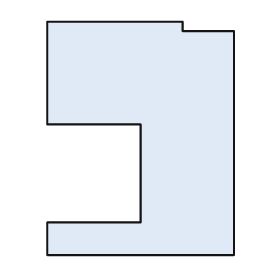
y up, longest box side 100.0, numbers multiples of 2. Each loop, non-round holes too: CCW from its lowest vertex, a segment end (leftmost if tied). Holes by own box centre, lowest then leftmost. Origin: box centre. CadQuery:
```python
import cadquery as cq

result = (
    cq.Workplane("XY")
    .moveTo(-40.0, -50.0)
    .lineTo(40.0, -50.0)
    .lineTo(40.0, 46.0)
    .lineTo(18.0, 46.0)
    .lineTo(18.0, 50.0)
    .lineTo(-40.0, 50.0)
    .lineTo(-40.0, 6.0)
    .lineTo(0.0, 6.0)
    .lineTo(0.0, -36.0)
    .lineTo(-40.0, -36.0)
    .close()
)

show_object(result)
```